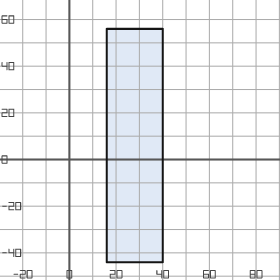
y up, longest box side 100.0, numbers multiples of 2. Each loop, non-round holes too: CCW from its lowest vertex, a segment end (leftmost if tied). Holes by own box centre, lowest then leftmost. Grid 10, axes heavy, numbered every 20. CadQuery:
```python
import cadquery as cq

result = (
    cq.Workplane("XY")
    .moveTo(16.0, -44.0)
    .lineTo(40.0, -44.0)
    .lineTo(40.0, 56.0)
    .lineTo(16.0, 56.0)
    .close()
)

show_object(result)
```